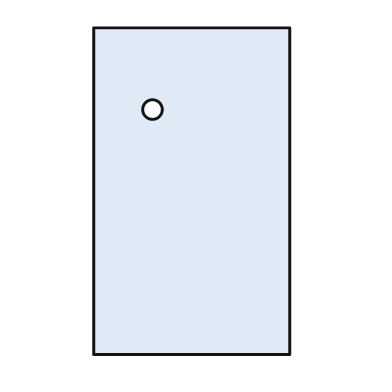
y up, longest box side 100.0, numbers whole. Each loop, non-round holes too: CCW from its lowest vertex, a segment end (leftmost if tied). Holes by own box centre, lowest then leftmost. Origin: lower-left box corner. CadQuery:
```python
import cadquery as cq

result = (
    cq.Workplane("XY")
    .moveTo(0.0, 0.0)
    .lineTo(60.0, 0.0)
    .lineTo(60.0, 100.0)
    .lineTo(0.0, 100.0)
    .close()
    .moveTo(18.0, 75.0)
    .circle(3.0)
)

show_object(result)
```